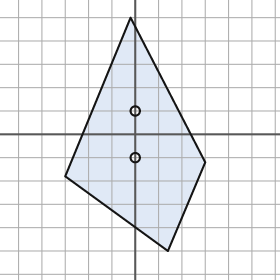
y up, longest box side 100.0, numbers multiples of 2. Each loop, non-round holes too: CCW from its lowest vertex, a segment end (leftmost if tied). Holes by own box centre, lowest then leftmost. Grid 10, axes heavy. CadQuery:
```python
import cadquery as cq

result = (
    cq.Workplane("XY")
    .moveTo(14.0, -50.0)
    .lineTo(30.0, -12.0)
    .lineTo(-2.0, 50.0)
    .lineTo(-30.0, -18.0)
    .close()
    .moveTo(0.0, -10.0)
    .circle(2.0)
    .moveTo(0.0, 10.0)
    .circle(2.0)
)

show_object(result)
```